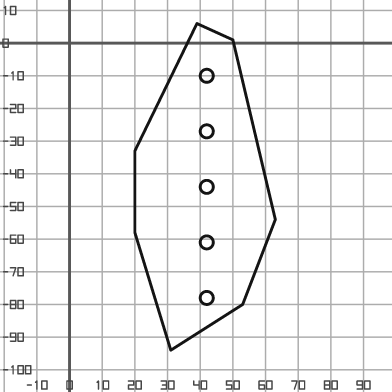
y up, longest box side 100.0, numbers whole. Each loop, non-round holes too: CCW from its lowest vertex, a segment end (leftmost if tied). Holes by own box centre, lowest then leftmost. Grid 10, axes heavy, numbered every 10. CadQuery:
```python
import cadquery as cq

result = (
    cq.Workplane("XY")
    .moveTo(31.0, -94.0)
    .lineTo(53.0, -80.0)
    .lineTo(63.0, -54.0)
    .lineTo(50.0, 1.0)
    .lineTo(39.0, 6.0)
    .lineTo(20.0, -33.0)
    .lineTo(20.0, -58.0)
    .close()
    .moveTo(42.0, -78.0)
    .circle(2.0)
    .moveTo(42.0, -61.0)
    .circle(2.0)
    .moveTo(42.0, -44.0)
    .circle(2.0)
    .moveTo(42.0, -27.0)
    .circle(2.0)
    .moveTo(42.0, -10.0)
    .circle(2.0)
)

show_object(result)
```